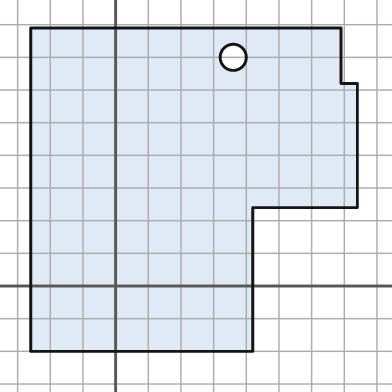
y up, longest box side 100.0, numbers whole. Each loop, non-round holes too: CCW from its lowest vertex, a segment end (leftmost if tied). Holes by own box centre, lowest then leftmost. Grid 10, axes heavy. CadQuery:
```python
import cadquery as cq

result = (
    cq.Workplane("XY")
    .moveTo(-26.0, -20.0)
    .lineTo(42.0, -20.0)
    .lineTo(42.0, 24.0)
    .lineTo(74.0, 24.0)
    .lineTo(74.0, 62.0)
    .lineTo(69.0, 62.0)
    .lineTo(69.0, 79.0)
    .lineTo(-26.0, 79.0)
    .close()
    .moveTo(36.0, 70.0)
    .circle(4.0)
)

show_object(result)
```